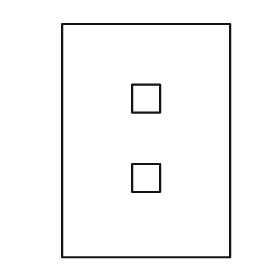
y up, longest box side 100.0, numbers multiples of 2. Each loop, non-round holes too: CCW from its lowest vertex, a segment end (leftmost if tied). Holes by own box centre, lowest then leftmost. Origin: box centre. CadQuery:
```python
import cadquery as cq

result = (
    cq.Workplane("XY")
    .moveTo(-36.0, -50.0)
    .lineTo(36.0, -50.0)
    .lineTo(36.0, 50.0)
    .lineTo(-36.0, 50.0)
    .close()
    .moveTo(-6.0, -22.0)
    .lineTo(6.0, -22.0)
    .lineTo(6.0, -10.0)
    .lineTo(-6.0, -10.0)
    .close()
    .moveTo(-6.0, 12.0)
    .lineTo(6.0, 12.0)
    .lineTo(6.0, 24.0)
    .lineTo(-6.0, 24.0)
    .close()
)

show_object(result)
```